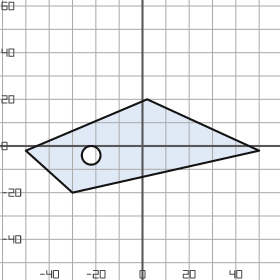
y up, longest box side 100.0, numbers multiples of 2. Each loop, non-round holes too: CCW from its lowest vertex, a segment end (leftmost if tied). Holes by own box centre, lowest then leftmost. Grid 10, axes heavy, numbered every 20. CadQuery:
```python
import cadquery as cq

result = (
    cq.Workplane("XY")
    .moveTo(-30.0, -20.0)
    .lineTo(50.0, -2.0)
    .lineTo(2.0, 20.0)
    .lineTo(-50.0, -2.0)
    .close()
    .moveTo(-22.0, -4.0)
    .circle(4.0)
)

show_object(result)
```